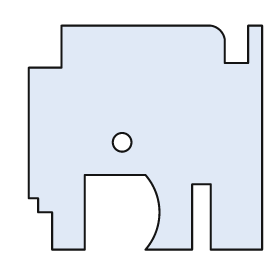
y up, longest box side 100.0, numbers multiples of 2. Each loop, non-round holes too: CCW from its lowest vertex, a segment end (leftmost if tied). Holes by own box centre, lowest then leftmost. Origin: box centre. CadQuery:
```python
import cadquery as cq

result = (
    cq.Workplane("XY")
    .moveTo(-40.0, -48.0)
    .lineTo(-26.0, -48.0)
    .lineTo(-26.0, -16.0)
    .lineTo(0.0, -16.0)
    .threePointArc((6.0, -32.0), (0.0, -48.0))
    .lineTo(20.0, -48.0)
    .lineTo(20.0, -20.0)
    .lineTo(28.0, -20.0)
    .lineTo(28.0, -48.0)
    .lineTo(50.0, -48.0)
    .lineTo(50.0, 48.0)
    .lineTo(44.0, 48.0)
    .lineTo(44.0, 32.0)
    .lineTo(34.0, 32.0)
    .lineTo(34.0, 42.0)
    .threePointArc((32.0, 46.0), (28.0, 48.0))
    .lineTo(-36.0, 48.0)
    .lineTo(-36.0, 30.0)
    .lineTo(-50.0, 30.0)
    .lineTo(-50.0, -26.0)
    .lineTo(-46.0, -26.0)
    .lineTo(-46.0, -32.0)
    .lineTo(-40.0, -32.0)
    .close()
    .moveTo(-10.0, -2.0)
    .circle(4.0)
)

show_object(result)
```